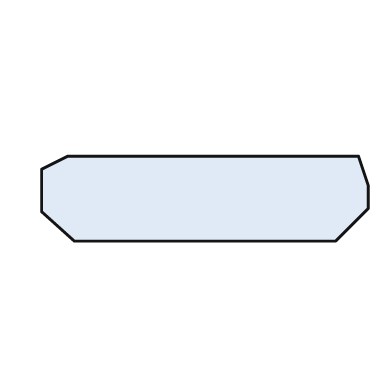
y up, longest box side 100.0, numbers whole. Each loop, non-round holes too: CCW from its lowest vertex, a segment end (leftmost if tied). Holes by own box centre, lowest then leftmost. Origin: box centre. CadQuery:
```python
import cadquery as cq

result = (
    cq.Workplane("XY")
    .moveTo(-40.0, -13.0)
    .lineTo(40.0, -13.0)
    .lineTo(50.0, -3.0)
    .lineTo(50.0, 4.0)
    .lineTo(47.0, 13.0)
    .lineTo(-42.0, 13.0)
    .lineTo(-50.0, 9.0)
    .lineTo(-50.0, -4.0)
    .close()
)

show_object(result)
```